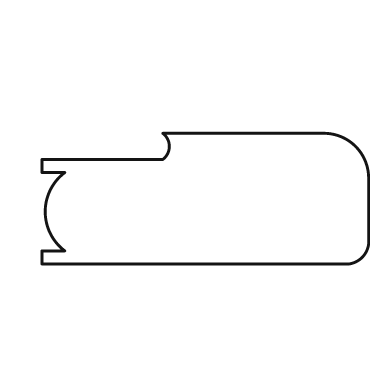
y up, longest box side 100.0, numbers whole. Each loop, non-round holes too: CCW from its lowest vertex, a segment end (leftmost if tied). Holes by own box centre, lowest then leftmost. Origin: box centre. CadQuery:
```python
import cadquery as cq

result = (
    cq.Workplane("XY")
    .moveTo(-50.0, -20.0)
    .lineTo(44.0, -20.0)
    .threePointArc((48.0, -18.0), (50.0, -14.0))
    .lineTo(50.0, 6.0)
    .threePointArc((46.0, 16.0), (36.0, 20.0))
    .lineTo(-13.0, 20.0)
    .threePointArc((-11.0, 16.0), (-13.0, 12.0))
    .lineTo(-50.0, 12.0)
    .lineTo(-50.0, 8.0)
    .lineTo(-43.0, 8.0)
    .threePointArc((-49.0, -4.0), (-43.0, -16.0))
    .lineTo(-50.0, -16.0)
    .close()
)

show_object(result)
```